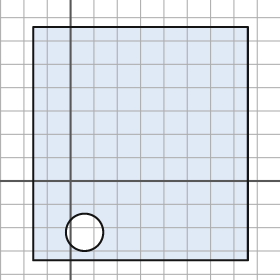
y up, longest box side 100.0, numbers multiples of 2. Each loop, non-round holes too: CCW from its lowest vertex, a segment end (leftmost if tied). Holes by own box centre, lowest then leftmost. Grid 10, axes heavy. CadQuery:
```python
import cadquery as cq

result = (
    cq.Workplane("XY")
    .moveTo(-16.0, -34.0)
    .lineTo(76.0, -34.0)
    .lineTo(76.0, 66.0)
    .lineTo(-16.0, 66.0)
    .close()
    .moveTo(6.0, -22.0)
    .circle(8.0)
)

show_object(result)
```